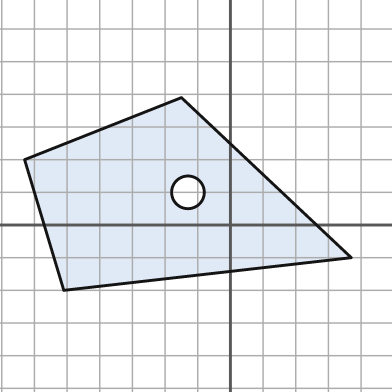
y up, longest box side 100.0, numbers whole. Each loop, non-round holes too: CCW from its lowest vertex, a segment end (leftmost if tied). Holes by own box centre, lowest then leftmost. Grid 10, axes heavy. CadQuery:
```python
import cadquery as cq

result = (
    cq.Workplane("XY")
    .moveTo(-51.0, -20.0)
    .lineTo(37.0, -10.0)
    .lineTo(-15.0, 39.0)
    .lineTo(-63.0, 20.0)
    .close()
    .moveTo(-13.0, 10.0)
    .circle(5.0)
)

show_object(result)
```